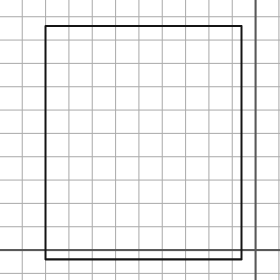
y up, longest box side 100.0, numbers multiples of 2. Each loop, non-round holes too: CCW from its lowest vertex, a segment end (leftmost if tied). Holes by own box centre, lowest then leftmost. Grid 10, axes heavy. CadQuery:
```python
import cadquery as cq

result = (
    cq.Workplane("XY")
    .moveTo(-90.0, -4.0)
    .lineTo(-6.0, -4.0)
    .lineTo(-6.0, 96.0)
    .lineTo(-90.0, 96.0)
    .close()
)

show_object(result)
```